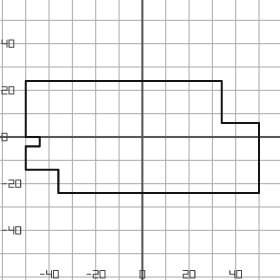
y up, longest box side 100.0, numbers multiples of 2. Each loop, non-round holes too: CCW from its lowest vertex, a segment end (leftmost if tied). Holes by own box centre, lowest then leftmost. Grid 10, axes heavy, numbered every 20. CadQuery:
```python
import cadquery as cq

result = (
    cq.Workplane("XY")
    .moveTo(-36.0, -24.0)
    .lineTo(50.0, -24.0)
    .lineTo(50.0, 6.0)
    .lineTo(34.0, 6.0)
    .lineTo(34.0, 24.0)
    .lineTo(-50.0, 24.0)
    .lineTo(-50.0, 0.0)
    .lineTo(-44.0, 0.0)
    .lineTo(-44.0, -4.0)
    .lineTo(-50.0, -4.0)
    .lineTo(-50.0, -14.0)
    .lineTo(-36.0, -14.0)
    .close()
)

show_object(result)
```